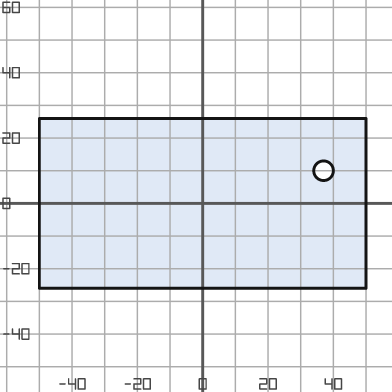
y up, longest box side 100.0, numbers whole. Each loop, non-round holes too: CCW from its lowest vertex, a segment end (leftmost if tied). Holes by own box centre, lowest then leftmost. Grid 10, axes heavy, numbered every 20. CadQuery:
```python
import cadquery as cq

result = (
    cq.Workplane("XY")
    .moveTo(-50.0, -26.0)
    .lineTo(50.0, -26.0)
    .lineTo(50.0, 26.0)
    .lineTo(-50.0, 26.0)
    .close()
    .moveTo(37.0, 10.0)
    .circle(3.0)
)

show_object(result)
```